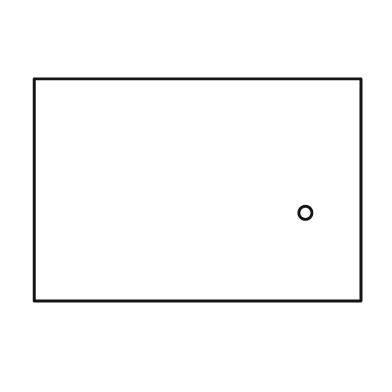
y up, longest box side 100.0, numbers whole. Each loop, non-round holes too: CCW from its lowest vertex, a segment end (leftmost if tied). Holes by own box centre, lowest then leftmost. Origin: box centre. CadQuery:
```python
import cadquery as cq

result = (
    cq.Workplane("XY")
    .moveTo(-50.0, -34.0)
    .lineTo(50.0, -34.0)
    .lineTo(50.0, 34.0)
    .lineTo(-50.0, 34.0)
    .close()
    .moveTo(33.0, -7.0)
    .circle(2.0)
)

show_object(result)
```